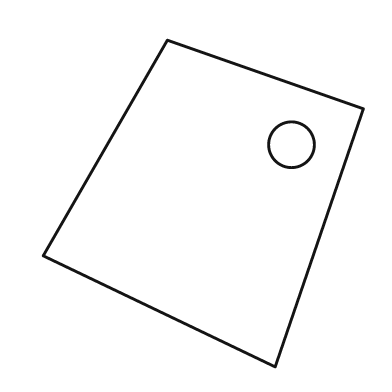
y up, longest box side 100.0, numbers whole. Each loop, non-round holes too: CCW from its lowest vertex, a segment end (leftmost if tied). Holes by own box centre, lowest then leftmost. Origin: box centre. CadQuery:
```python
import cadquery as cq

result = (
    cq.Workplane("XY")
    .moveTo(22.0, -50.0)
    .lineTo(49.0, 29.0)
    .lineTo(-11.0, 50.0)
    .lineTo(-49.0, -16.0)
    .close()
    .moveTo(27.0, 18.0)
    .circle(7.0)
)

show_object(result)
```